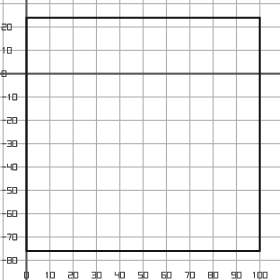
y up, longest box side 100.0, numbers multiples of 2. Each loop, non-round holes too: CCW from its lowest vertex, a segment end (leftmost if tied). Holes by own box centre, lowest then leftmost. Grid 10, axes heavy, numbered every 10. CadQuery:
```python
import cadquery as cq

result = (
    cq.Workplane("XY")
    .moveTo(0.0, -76.0)
    .lineTo(100.0, -76.0)
    .lineTo(100.0, 24.0)
    .lineTo(0.0, 24.0)
    .close()
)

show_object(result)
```